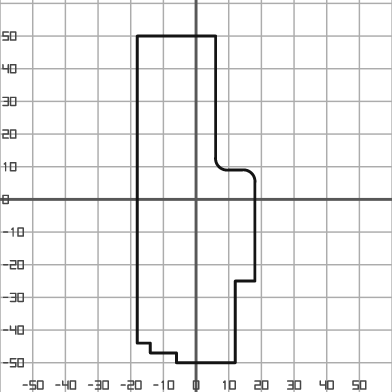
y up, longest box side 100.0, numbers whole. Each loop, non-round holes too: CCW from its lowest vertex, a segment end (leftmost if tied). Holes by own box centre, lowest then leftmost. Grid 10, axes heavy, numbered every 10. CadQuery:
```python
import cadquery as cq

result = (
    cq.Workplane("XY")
    .moveTo(-6.0, -50.0)
    .lineTo(12.0, -50.0)
    .lineTo(12.0, -25.0)
    .lineTo(18.0, -25.0)
    .lineTo(18.0, 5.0)
    .threePointArc((17.0, 8.0), (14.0, 9.0))
    .lineTo(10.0, 9.0)
    .threePointArc((7.0, 10.0), (6.0, 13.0))
    .lineTo(6.0, 50.0)
    .lineTo(-18.0, 50.0)
    .lineTo(-18.0, -44.0)
    .lineTo(-14.0, -44.0)
    .lineTo(-14.0, -47.0)
    .lineTo(-6.0, -47.0)
    .close()
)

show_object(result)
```